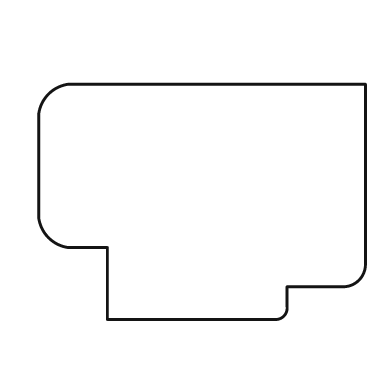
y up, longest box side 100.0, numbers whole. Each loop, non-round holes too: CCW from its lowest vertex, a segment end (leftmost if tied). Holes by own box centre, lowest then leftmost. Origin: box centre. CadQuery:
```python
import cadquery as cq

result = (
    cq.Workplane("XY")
    .moveTo(-29.0, -36.0)
    .lineTo(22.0, -36.0)
    .threePointArc((25.0, -35.0), (26.0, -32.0))
    .lineTo(26.0, -26.0)
    .lineTo(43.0, -26.0)
    .threePointArc((48.0, -24.0), (50.0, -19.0))
    .lineTo(50.0, 36.0)
    .lineTo(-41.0, 36.0)
    .threePointArc((-47.0, 33.0), (-50.0, 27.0))
    .lineTo(-50.0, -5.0)
    .threePointArc((-47.0, -11.0), (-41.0, -14.0))
    .lineTo(-29.0, -14.0)
    .close()
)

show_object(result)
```